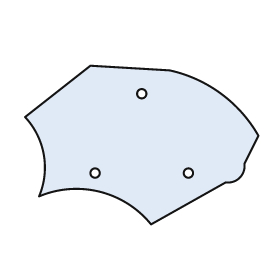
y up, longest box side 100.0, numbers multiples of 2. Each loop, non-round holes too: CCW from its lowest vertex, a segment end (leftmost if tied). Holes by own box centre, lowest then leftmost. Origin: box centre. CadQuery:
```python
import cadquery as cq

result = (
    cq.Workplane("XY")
    .moveTo(4.0, -34.0)
    .lineTo(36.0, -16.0)
    .threePointArc((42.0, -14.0), (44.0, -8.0))
    .lineTo(50.0, 4.0)
    .threePointArc((34.0, 22.0), (12.0, 32.0))
    .lineTo(-22.0, 34.0)
    .lineTo(-50.0, 12.0)
    .threePointArc((-42.0, -4.0), (-44.0, -22.0))
    .threePointArc((-18.0, -20.0), (4.0, -34.0))
    .close()
    .moveTo(-20.0, -12.0)
    .circle(2.0)
    .moveTo(20.0, -12.0)
    .circle(2.0)
    .moveTo(0.0, 22.0)
    .circle(2.0)
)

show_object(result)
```